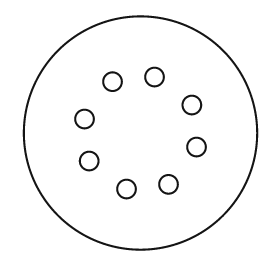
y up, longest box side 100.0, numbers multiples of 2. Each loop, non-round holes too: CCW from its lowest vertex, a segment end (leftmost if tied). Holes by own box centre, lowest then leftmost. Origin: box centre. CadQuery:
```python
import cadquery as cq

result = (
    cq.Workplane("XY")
    .moveTo(0.0, 0.0)
    .circle(50.0)
    .moveTo(-6.0, -24.0)
    .circle(4.0)
    .moveTo(12.0, -22.0)
    .circle(4.0)
    .moveTo(-22.0, -12.0)
    .circle(4.0)
    .moveTo(24.0, -6.0)
    .circle(4.0)
    .moveTo(-24.0, 6.0)
    .circle(4.0)
    .moveTo(22.0, 12.0)
    .circle(4.0)
    .moveTo(-12.0, 22.0)
    .circle(4.0)
    .moveTo(6.0, 24.0)
    .circle(4.0)
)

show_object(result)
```